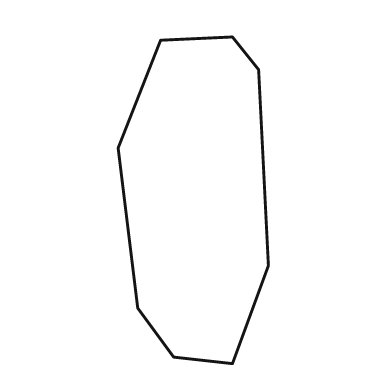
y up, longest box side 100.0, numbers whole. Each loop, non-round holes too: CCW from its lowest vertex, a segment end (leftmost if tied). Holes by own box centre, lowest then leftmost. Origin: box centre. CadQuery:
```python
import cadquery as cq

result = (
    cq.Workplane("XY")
    .moveTo(12.0, -50.0)
    .lineTo(23.0, -20.0)
    .lineTo(20.0, 40.0)
    .lineTo(12.0, 50.0)
    .lineTo(-10.0, 49.0)
    .lineTo(-23.0, 16.0)
    .lineTo(-17.0, -33.0)
    .lineTo(-6.0, -48.0)
    .close()
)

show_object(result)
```